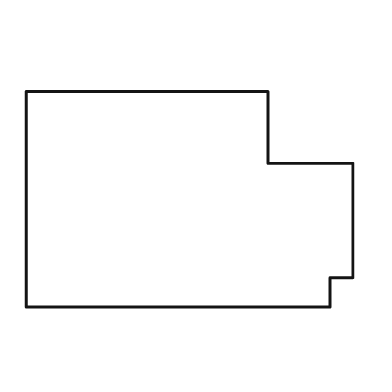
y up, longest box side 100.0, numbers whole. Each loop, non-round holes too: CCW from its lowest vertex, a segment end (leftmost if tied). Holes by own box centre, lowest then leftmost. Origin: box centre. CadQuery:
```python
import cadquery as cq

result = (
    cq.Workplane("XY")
    .moveTo(-50.0, -33.0)
    .lineTo(43.0, -33.0)
    .lineTo(43.0, -24.0)
    .lineTo(50.0, -24.0)
    .lineTo(50.0, 11.0)
    .lineTo(24.0, 11.0)
    .lineTo(24.0, 33.0)
    .lineTo(-50.0, 33.0)
    .close()
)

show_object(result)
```